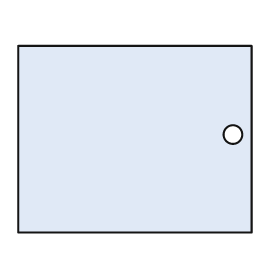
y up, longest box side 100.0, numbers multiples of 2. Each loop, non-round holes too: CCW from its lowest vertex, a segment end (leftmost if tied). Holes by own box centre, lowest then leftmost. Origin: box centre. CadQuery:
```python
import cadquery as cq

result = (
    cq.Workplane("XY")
    .moveTo(-50.0, -40.0)
    .lineTo(50.0, -40.0)
    .lineTo(50.0, 40.0)
    .lineTo(-50.0, 40.0)
    .close()
    .moveTo(42.0, 2.0)
    .circle(4.0)
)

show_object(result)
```